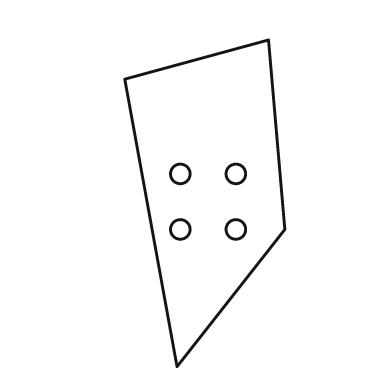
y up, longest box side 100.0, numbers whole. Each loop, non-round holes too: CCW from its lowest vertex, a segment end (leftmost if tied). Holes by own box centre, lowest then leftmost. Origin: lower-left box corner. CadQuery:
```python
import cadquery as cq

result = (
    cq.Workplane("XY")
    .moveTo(16.0, 0.0)
    .lineTo(49.0, 42.0)
    .lineTo(44.0, 100.0)
    .lineTo(0.0, 88.0)
    .close()
    .moveTo(17.0, 42.0)
    .circle(3.0)
    .moveTo(34.0, 42.0)
    .circle(3.0)
    .moveTo(17.0, 59.0)
    .circle(3.0)
    .moveTo(34.0, 59.0)
    .circle(3.0)
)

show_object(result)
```